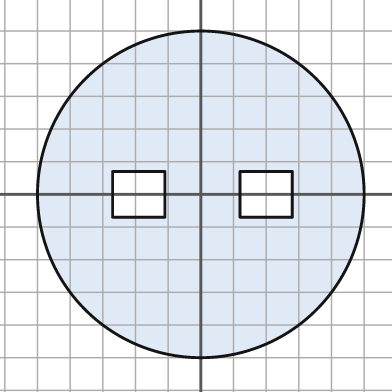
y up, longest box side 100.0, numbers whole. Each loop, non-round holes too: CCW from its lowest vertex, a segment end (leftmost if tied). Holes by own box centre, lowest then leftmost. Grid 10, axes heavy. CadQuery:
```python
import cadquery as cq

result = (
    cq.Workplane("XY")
    .moveTo(0.0, 0.0)
    .circle(50.0)
    .moveTo(-27.0, -7.0)
    .lineTo(-11.0, -7.0)
    .lineTo(-11.0, 7.0)
    .lineTo(-27.0, 7.0)
    .close()
    .moveTo(12.0, -7.0)
    .lineTo(28.0, -7.0)
    .lineTo(28.0, 7.0)
    .lineTo(12.0, 7.0)
    .close()
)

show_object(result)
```